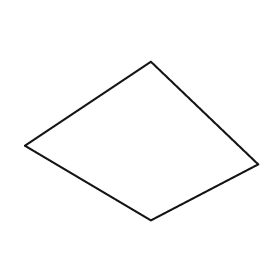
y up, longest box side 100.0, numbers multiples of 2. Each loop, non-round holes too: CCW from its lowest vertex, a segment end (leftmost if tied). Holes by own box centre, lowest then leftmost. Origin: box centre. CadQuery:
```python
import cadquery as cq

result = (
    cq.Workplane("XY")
    .moveTo(4.0, -34.0)
    .lineTo(50.0, -10.0)
    .lineTo(4.0, 34.0)
    .lineTo(-50.0, -2.0)
    .close()
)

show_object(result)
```